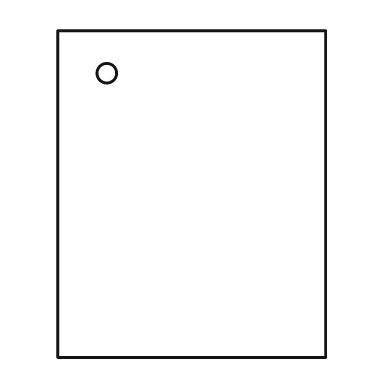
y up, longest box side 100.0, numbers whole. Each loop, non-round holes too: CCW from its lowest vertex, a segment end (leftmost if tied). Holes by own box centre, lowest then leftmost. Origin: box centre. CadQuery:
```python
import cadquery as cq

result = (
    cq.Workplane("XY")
    .moveTo(-41.0, -50.0)
    .lineTo(41.0, -50.0)
    .lineTo(41.0, 50.0)
    .lineTo(-41.0, 50.0)
    .close()
    .moveTo(-26.0, 37.0)
    .circle(3.0)
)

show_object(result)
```